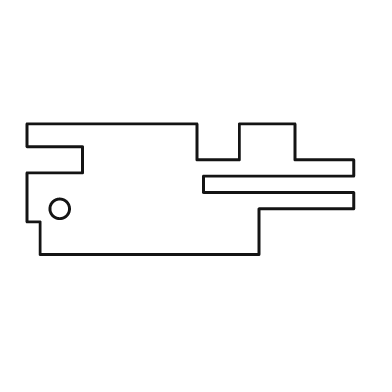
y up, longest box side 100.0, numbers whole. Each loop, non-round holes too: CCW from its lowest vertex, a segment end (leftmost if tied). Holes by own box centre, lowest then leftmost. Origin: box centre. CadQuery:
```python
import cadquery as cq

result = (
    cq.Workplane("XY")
    .moveTo(-46.0, -20.0)
    .lineTo(21.0, -20.0)
    .lineTo(21.0, -6.0)
    .lineTo(50.0, -6.0)
    .lineTo(50.0, -1.0)
    .lineTo(4.0, -1.0)
    .lineTo(4.0, 4.0)
    .lineTo(50.0, 4.0)
    .lineTo(50.0, 9.0)
    .lineTo(32.0, 9.0)
    .lineTo(32.0, 20.0)
    .lineTo(15.0, 20.0)
    .lineTo(15.0, 9.0)
    .lineTo(2.0, 9.0)
    .lineTo(2.0, 20.0)
    .lineTo(-50.0, 20.0)
    .lineTo(-50.0, 13.0)
    .lineTo(-33.0, 13.0)
    .lineTo(-33.0, 5.0)
    .lineTo(-50.0, 5.0)
    .lineTo(-50.0, -10.0)
    .lineTo(-46.0, -10.0)
    .close()
    .moveTo(-40.0, -6.0)
    .circle(3.0)
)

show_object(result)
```